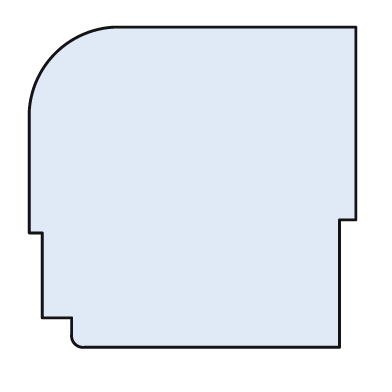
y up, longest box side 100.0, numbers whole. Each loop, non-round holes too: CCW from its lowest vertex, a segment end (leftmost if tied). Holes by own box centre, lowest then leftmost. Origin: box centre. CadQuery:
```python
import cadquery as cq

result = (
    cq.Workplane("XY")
    .moveTo(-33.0, -49.0)
    .lineTo(45.0, -49.0)
    .lineTo(45.0, -10.0)
    .lineTo(50.0, -10.0)
    .lineTo(50.0, 49.0)
    .lineTo(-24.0, 49.0)
    .threePointArc((-42.0, 41.0), (-50.0, 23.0))
    .lineTo(-50.0, -14.0)
    .lineTo(-46.0, -14.0)
    .lineTo(-46.0, -40.0)
    .lineTo(-37.0, -40.0)
    .lineTo(-37.0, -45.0)
    .threePointArc((-36.0, -48.0), (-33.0, -49.0))
    .close()
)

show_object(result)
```